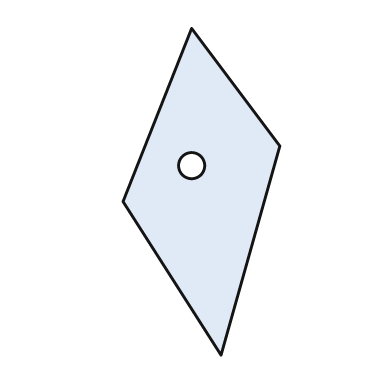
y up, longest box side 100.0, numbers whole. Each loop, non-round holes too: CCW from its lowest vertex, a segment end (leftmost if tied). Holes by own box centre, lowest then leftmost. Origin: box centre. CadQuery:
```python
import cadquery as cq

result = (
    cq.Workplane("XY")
    .moveTo(6.0, -50.0)
    .lineTo(24.0, 14.0)
    .lineTo(-3.0, 50.0)
    .lineTo(-24.0, -3.0)
    .close()
    .moveTo(-3.0, 8.0)
    .circle(4.0)
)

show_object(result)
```